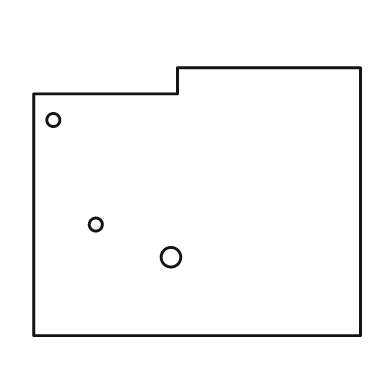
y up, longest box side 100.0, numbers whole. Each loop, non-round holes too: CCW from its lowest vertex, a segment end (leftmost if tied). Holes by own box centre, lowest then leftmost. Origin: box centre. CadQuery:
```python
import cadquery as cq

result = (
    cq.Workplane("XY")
    .moveTo(-50.0, -41.0)
    .lineTo(50.0, -41.0)
    .lineTo(50.0, 41.0)
    .lineTo(-6.0, 41.0)
    .lineTo(-6.0, 33.0)
    .lineTo(-50.0, 33.0)
    .close()
    .moveTo(-8.0, -17.0)
    .circle(3.0)
    .moveTo(-31.0, -7.0)
    .circle(2.0)
    .moveTo(-44.0, 25.0)
    .circle(2.0)
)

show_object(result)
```